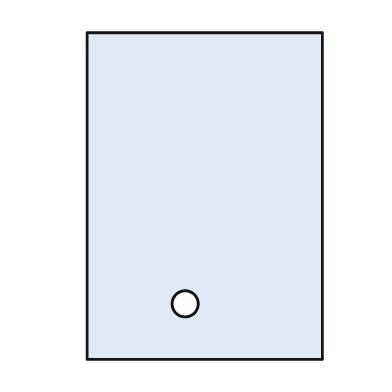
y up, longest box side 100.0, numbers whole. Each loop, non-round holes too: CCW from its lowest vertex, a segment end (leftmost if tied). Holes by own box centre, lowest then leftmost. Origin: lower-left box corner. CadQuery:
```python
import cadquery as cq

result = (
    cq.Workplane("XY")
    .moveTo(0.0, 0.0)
    .lineTo(72.0, 0.0)
    .lineTo(72.0, 100.0)
    .lineTo(0.0, 100.0)
    .close()
    .moveTo(30.0, 17.0)
    .circle(4.0)
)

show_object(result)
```